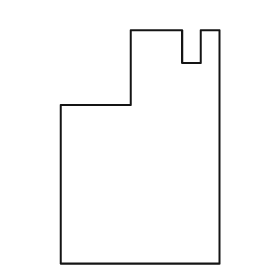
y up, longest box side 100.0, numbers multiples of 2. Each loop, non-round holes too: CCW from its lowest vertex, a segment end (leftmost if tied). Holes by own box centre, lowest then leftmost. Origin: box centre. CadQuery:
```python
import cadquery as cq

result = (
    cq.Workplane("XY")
    .moveTo(-34.0, -50.0)
    .lineTo(34.0, -50.0)
    .lineTo(34.0, 50.0)
    .lineTo(26.0, 50.0)
    .lineTo(26.0, 36.0)
    .lineTo(18.0, 36.0)
    .lineTo(18.0, 50.0)
    .lineTo(-4.0, 50.0)
    .lineTo(-4.0, 18.0)
    .lineTo(-34.0, 18.0)
    .close()
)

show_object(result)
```